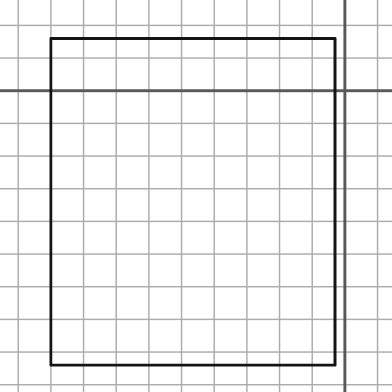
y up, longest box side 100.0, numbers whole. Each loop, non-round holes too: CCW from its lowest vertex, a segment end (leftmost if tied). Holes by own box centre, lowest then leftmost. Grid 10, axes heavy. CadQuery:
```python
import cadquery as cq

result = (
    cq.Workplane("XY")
    .moveTo(-90.0, -84.0)
    .lineTo(-3.0, -84.0)
    .lineTo(-3.0, 16.0)
    .lineTo(-90.0, 16.0)
    .close()
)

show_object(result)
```